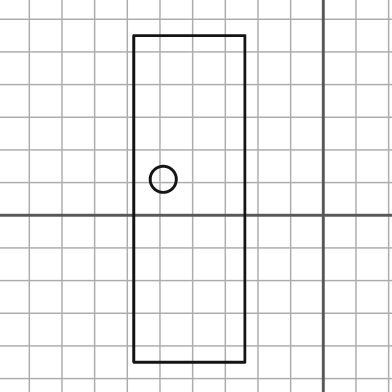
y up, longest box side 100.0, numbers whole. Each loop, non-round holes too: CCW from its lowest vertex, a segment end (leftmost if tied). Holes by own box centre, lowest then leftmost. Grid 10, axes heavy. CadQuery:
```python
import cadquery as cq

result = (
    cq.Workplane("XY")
    .moveTo(-58.0, -45.0)
    .lineTo(-24.0, -45.0)
    .lineTo(-24.0, 55.0)
    .lineTo(-58.0, 55.0)
    .close()
    .moveTo(-49.0, 11.0)
    .circle(4.0)
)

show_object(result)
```